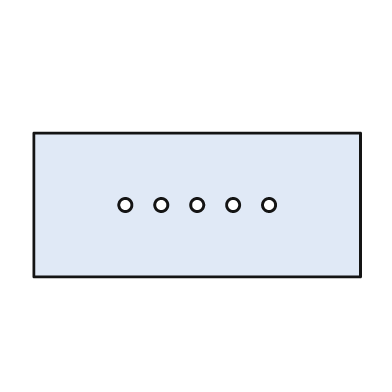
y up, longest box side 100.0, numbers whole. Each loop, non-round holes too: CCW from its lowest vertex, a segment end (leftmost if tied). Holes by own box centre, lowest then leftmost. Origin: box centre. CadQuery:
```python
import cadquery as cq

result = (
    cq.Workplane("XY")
    .moveTo(-50.0, -22.0)
    .lineTo(50.0, -22.0)
    .lineTo(50.0, 22.0)
    .lineTo(-50.0, 22.0)
    .close()
    .moveTo(-22.0, 0.0)
    .circle(2.0)
    .moveTo(-11.0, 0.0)
    .circle(2.0)
    .moveTo(0.0, 0.0)
    .circle(2.0)
    .moveTo(11.0, 0.0)
    .circle(2.0)
    .moveTo(22.0, 0.0)
    .circle(2.0)
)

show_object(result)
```